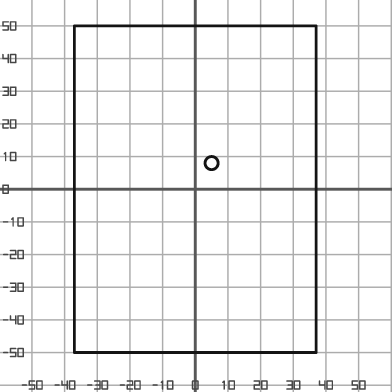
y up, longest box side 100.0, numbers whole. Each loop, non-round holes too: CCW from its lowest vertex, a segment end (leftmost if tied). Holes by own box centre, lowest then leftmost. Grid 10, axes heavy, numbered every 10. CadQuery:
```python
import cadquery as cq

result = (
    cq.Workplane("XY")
    .moveTo(-37.0, -50.0)
    .lineTo(37.0, -50.0)
    .lineTo(37.0, 50.0)
    .lineTo(-37.0, 50.0)
    .close()
    .moveTo(5.0, 8.0)
    .circle(2.0)
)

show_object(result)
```